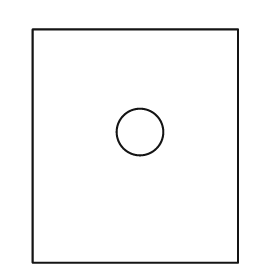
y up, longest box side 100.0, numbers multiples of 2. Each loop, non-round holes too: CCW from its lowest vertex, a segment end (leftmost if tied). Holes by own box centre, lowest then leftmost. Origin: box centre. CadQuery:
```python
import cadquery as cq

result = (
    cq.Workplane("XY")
    .moveTo(-44.0, -50.0)
    .lineTo(44.0, -50.0)
    .lineTo(44.0, 50.0)
    .lineTo(-44.0, 50.0)
    .close()
    .moveTo(2.0, 6.0)
    .circle(10.0)
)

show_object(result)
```